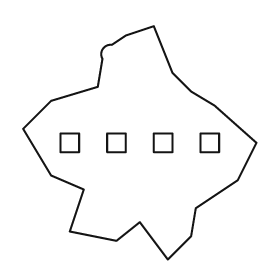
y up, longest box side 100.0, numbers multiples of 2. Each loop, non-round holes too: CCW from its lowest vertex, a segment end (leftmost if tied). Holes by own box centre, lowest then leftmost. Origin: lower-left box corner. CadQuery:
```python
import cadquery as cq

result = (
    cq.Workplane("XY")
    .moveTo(62.0, 0.0)
    .lineTo(72.0, 10.0)
    .lineTo(74.0, 22.0)
    .lineTo(92.0, 34.0)
    .lineTo(100.0, 50.0)
    .lineTo(82.0, 66.0)
    .lineTo(72.0, 72.0)
    .lineTo(64.0, 80.0)
    .lineTo(56.0, 100.0)
    .lineTo(44.0, 96.0)
    .lineTo(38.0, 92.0)
    .threePointArc((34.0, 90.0), (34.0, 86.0))
    .lineTo(32.0, 74.0)
    .lineTo(12.0, 68.0)
    .lineTo(0.0, 56.0)
    .lineTo(12.0, 36.0)
    .lineTo(26.0, 30.0)
    .lineTo(20.0, 12.0)
    .lineTo(40.0, 8.0)
    .lineTo(50.0, 16.0)
    .close()
    .moveTo(16.0, 46.0)
    .lineTo(24.0, 46.0)
    .lineTo(24.0, 54.0)
    .lineTo(16.0, 54.0)
    .close()
    .moveTo(36.0, 46.0)
    .lineTo(44.0, 46.0)
    .lineTo(44.0, 54.0)
    .lineTo(36.0, 54.0)
    .close()
    .moveTo(56.0, 46.0)
    .lineTo(64.0, 46.0)
    .lineTo(64.0, 54.0)
    .lineTo(56.0, 54.0)
    .close()
    .moveTo(76.0, 46.0)
    .lineTo(84.0, 46.0)
    .lineTo(84.0, 54.0)
    .lineTo(76.0, 54.0)
    .close()
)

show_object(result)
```